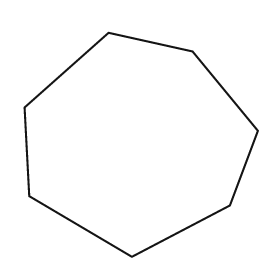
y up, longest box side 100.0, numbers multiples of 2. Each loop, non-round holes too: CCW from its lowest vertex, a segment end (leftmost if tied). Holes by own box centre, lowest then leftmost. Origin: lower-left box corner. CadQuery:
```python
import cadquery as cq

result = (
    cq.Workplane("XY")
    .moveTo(46.0, 0.0)
    .lineTo(88.0, 22.0)
    .lineTo(100.0, 54.0)
    .lineTo(72.0, 88.0)
    .lineTo(36.0, 96.0)
    .lineTo(0.0, 64.0)
    .lineTo(2.0, 26.0)
    .close()
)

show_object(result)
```